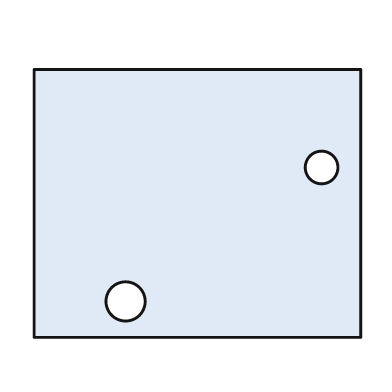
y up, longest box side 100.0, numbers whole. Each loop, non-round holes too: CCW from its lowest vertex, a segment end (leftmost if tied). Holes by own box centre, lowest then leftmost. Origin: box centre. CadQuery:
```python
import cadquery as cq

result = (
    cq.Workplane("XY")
    .moveTo(-50.0, -41.0)
    .lineTo(50.0, -41.0)
    .lineTo(50.0, 41.0)
    .lineTo(-50.0, 41.0)
    .close()
    .moveTo(-22.0, -30.0)
    .circle(6.0)
    .moveTo(38.0, 11.0)
    .circle(5.0)
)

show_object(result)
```